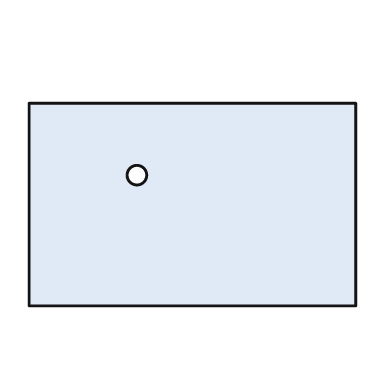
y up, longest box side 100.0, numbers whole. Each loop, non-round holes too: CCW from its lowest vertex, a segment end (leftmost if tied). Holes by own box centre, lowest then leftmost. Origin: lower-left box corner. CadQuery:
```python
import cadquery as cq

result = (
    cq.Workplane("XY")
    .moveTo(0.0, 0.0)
    .lineTo(100.0, 0.0)
    .lineTo(100.0, 62.0)
    .lineTo(0.0, 62.0)
    .close()
    .moveTo(33.0, 40.0)
    .circle(3.0)
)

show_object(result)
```